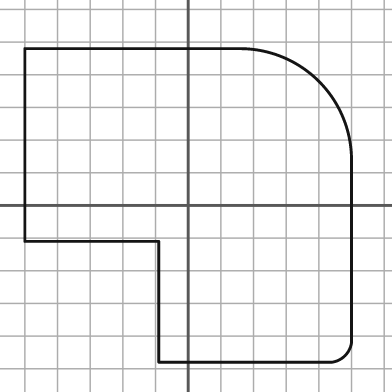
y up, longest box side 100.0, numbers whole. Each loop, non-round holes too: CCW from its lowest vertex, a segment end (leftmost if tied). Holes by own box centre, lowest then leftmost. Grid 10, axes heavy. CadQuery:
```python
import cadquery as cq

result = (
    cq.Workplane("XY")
    .moveTo(-9.0, -48.0)
    .lineTo(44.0, -48.0)
    .threePointArc((48.0, -46.0), (50.0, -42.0))
    .lineTo(50.0, 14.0)
    .threePointArc((40.0, 38.0), (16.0, 48.0))
    .lineTo(-50.0, 48.0)
    .lineTo(-50.0, -11.0)
    .lineTo(-9.0, -11.0)
    .close()
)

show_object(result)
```